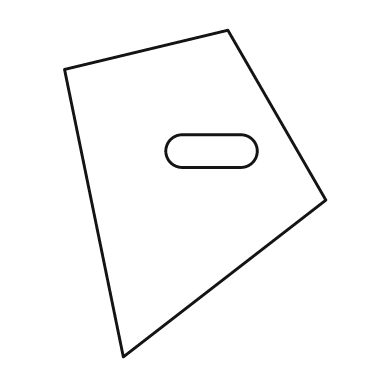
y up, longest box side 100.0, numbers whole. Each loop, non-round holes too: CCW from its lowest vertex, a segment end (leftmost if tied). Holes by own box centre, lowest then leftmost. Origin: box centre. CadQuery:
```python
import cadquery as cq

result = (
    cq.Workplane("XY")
    .moveTo(-22.0, -50.0)
    .lineTo(40.0, -2.0)
    .lineTo(10.0, 50.0)
    .lineTo(-40.0, 38.0)
    .close()
    .moveTo(-4.0, 8.0)
    .lineTo(14.0, 8.0)
    .threePointArc((19.0, 13.0), (14.0, 18.0))
    .lineTo(-4.0, 18.0)
    .threePointArc((-9.0, 13.0), (-4.0, 8.0))
    .close()
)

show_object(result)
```